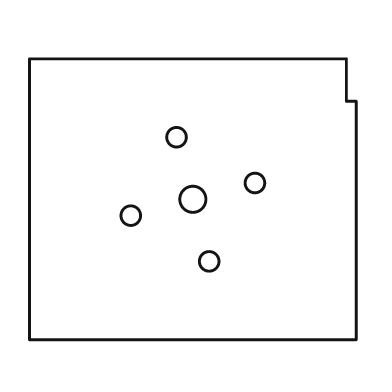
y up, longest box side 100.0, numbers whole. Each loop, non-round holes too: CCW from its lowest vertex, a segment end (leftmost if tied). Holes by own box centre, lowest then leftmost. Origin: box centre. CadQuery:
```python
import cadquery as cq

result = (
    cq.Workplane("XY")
    .moveTo(-50.0, -43.0)
    .lineTo(50.0, -43.0)
    .lineTo(50.0, 30.0)
    .lineTo(47.0, 30.0)
    .lineTo(47.0, 43.0)
    .lineTo(-50.0, 43.0)
    .close()
    .moveTo(5.0, -19.0)
    .circle(3.0)
    .moveTo(-19.0, -5.0)
    .circle(3.0)
    .moveTo(0.0, 0.0)
    .circle(4.0)
    .moveTo(19.0, 5.0)
    .circle(3.0)
    .moveTo(-5.0, 19.0)
    .circle(3.0)
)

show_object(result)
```